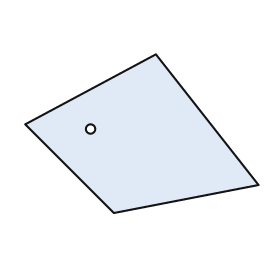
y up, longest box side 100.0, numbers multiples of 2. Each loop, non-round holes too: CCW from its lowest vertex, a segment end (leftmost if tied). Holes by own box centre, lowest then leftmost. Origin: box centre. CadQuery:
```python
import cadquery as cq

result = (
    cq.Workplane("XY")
    .moveTo(-12.0, -34.0)
    .lineTo(50.0, -22.0)
    .lineTo(6.0, 34.0)
    .lineTo(-50.0, 4.0)
    .close()
    .moveTo(-22.0, 2.0)
    .circle(2.0)
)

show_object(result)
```